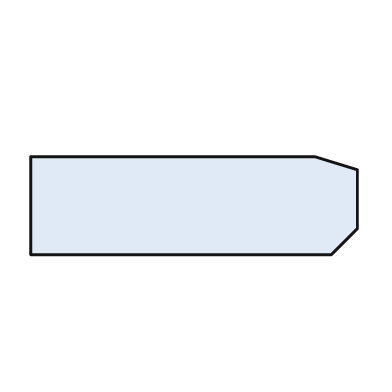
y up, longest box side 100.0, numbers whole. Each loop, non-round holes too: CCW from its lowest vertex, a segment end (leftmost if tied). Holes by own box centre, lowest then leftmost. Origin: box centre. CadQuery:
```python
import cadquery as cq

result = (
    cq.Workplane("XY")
    .moveTo(-50.0, -15.0)
    .lineTo(42.0, -15.0)
    .lineTo(50.0, -7.0)
    .lineTo(50.0, 11.0)
    .lineTo(37.0, 15.0)
    .lineTo(-50.0, 15.0)
    .close()
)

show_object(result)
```